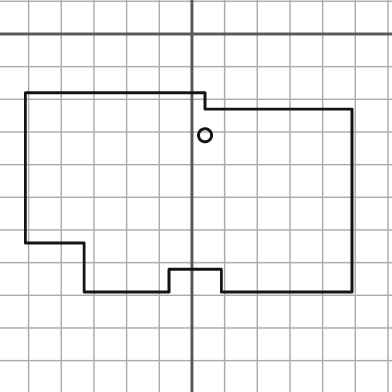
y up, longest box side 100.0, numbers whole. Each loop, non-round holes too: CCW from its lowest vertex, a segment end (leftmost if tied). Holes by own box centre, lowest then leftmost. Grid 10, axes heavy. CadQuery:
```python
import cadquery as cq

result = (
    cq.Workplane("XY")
    .moveTo(-33.0, -79.0)
    .lineTo(-7.0, -79.0)
    .lineTo(-7.0, -72.0)
    .lineTo(9.0, -72.0)
    .lineTo(9.0, -79.0)
    .lineTo(49.0, -79.0)
    .lineTo(49.0, -23.0)
    .lineTo(4.0, -23.0)
    .lineTo(4.0, -18.0)
    .lineTo(-51.0, -18.0)
    .lineTo(-51.0, -64.0)
    .lineTo(-33.0, -64.0)
    .close()
    .moveTo(4.0, -31.0)
    .circle(2.0)
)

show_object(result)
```